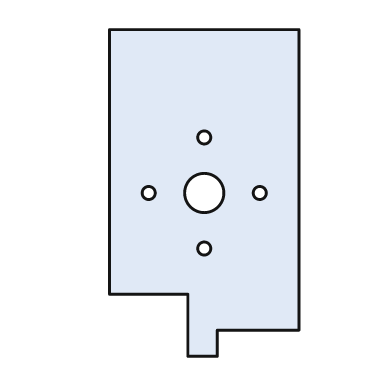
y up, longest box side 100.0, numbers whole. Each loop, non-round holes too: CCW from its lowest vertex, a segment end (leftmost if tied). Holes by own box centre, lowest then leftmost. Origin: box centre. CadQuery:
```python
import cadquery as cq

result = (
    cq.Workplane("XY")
    .moveTo(-5.0, -50.0)
    .lineTo(4.0, -50.0)
    .lineTo(4.0, -42.0)
    .lineTo(29.0, -42.0)
    .lineTo(29.0, 50.0)
    .lineTo(-29.0, 50.0)
    .lineTo(-29.0, -31.0)
    .lineTo(-5.0, -31.0)
    .close()
    .moveTo(0.0, -17.0)
    .circle(2.0)
    .moveTo(-17.0, 0.0)
    .circle(2.0)
    .moveTo(0.0, 0.0)
    .circle(6.0)
    .moveTo(17.0, 0.0)
    .circle(2.0)
    .moveTo(0.0, 17.0)
    .circle(2.0)
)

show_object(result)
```